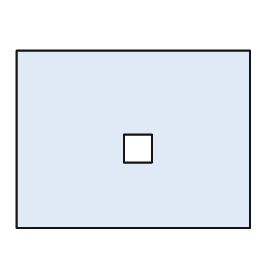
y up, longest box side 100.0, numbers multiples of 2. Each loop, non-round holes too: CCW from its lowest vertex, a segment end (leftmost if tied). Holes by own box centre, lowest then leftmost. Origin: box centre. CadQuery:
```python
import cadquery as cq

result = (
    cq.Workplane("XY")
    .moveTo(-50.0, -38.0)
    .lineTo(50.0, -38.0)
    .lineTo(50.0, 38.0)
    .lineTo(-50.0, 38.0)
    .close()
    .moveTo(-4.0, -10.0)
    .lineTo(8.0, -10.0)
    .lineTo(8.0, 2.0)
    .lineTo(-4.0, 2.0)
    .close()
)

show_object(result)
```